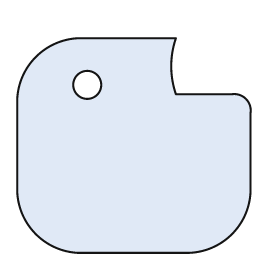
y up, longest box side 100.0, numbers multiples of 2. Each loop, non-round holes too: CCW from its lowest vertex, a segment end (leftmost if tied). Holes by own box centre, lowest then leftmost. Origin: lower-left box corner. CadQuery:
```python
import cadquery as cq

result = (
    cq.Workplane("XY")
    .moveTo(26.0, 0.0)
    .lineTo(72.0, 0.0)
    .threePointArc((92.0, 8.0), (100.0, 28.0))
    .lineTo(100.0, 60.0)
    .threePointArc((98.0, 66.0), (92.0, 68.0))
    .lineTo(68.0, 68.0)
    .threePointArc((66.0, 80.0), (68.0, 92.0))
    .lineTo(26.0, 92.0)
    .threePointArc((8.0, 84.0), (0.0, 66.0))
    .lineTo(0.0, 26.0)
    .threePointArc((8.0, 8.0), (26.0, 0.0))
    .close()
    .moveTo(30.0, 72.0)
    .circle(6.0)
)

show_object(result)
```